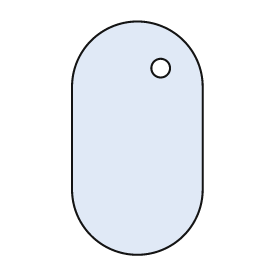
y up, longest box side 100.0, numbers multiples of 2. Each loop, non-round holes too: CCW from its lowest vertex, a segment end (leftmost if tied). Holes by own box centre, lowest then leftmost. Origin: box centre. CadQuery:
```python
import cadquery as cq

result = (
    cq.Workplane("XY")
    .moveTo(-28.0, -22.0)
    .threePointArc((0.0, -50.0), (28.0, -22.0))
    .lineTo(28.0, 22.0)
    .threePointArc((0.0, 50.0), (-28.0, 22.0))
    .close()
    .moveTo(10.0, 30.0)
    .circle(4.0)
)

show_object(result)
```